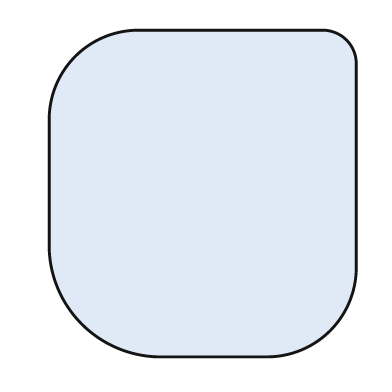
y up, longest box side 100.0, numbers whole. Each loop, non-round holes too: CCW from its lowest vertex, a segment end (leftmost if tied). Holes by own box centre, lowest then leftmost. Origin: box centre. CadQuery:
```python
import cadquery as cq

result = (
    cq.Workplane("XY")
    .moveTo(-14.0, -50.0)
    .lineTo(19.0, -50.0)
    .threePointArc((39.0, -42.0), (47.0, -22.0))
    .lineTo(47.0, 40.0)
    .threePointArc((44.0, 47.0), (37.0, 50.0))
    .lineTo(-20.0, 50.0)
    .threePointArc((-39.0, 42.0), (-47.0, 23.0))
    .lineTo(-47.0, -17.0)
    .threePointArc((-37.0, -40.0), (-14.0, -50.0))
    .close()
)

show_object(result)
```